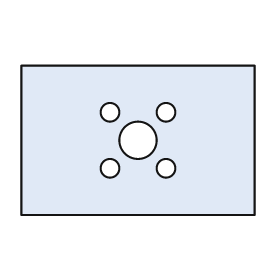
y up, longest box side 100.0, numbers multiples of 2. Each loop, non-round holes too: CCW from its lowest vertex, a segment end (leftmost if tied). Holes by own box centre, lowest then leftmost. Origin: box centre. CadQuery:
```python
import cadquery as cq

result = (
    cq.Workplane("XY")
    .moveTo(-50.0, -32.0)
    .lineTo(50.0, -32.0)
    .lineTo(50.0, 32.0)
    .lineTo(-50.0, 32.0)
    .close()
    .moveTo(-12.0, -12.0)
    .circle(4.0)
    .moveTo(12.0, -12.0)
    .circle(4.0)
    .moveTo(0.0, 0.0)
    .circle(8.0)
    .moveTo(-12.0, 12.0)
    .circle(4.0)
    .moveTo(12.0, 12.0)
    .circle(4.0)
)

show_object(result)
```